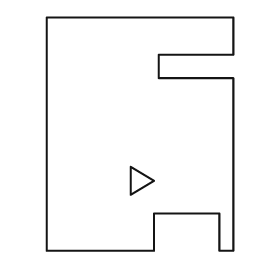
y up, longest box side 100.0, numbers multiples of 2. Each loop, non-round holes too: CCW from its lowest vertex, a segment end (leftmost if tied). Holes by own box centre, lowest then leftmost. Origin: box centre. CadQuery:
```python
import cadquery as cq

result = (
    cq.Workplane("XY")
    .moveTo(-40.0, -50.0)
    .lineTo(6.0, -50.0)
    .lineTo(6.0, -34.0)
    .lineTo(34.0, -34.0)
    .lineTo(34.0, -50.0)
    .lineTo(40.0, -50.0)
    .lineTo(40.0, 24.0)
    .lineTo(8.0, 24.0)
    .lineTo(8.0, 34.0)
    .lineTo(40.0, 34.0)
    .lineTo(40.0, 50.0)
    .lineTo(-40.0, 50.0)
    .close()
    .moveTo(-4.0, -26.0)
    .lineTo(6.0, -20.0)
    .lineTo(-4.0, -14.0)
    .close()
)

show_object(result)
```